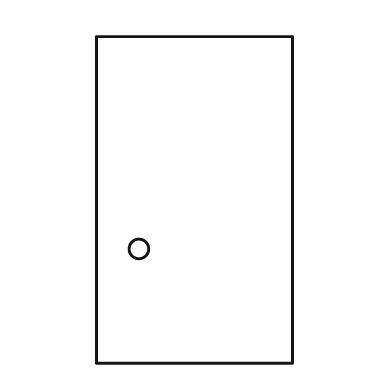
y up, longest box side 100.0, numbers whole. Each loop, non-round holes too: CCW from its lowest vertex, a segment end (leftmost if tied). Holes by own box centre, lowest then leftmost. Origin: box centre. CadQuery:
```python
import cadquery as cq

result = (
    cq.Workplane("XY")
    .moveTo(-30.0, -50.0)
    .lineTo(30.0, -50.0)
    .lineTo(30.0, 50.0)
    .lineTo(-30.0, 50.0)
    .close()
    .moveTo(-17.0, -15.0)
    .circle(3.0)
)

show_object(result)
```